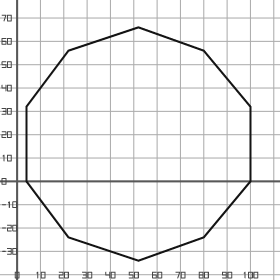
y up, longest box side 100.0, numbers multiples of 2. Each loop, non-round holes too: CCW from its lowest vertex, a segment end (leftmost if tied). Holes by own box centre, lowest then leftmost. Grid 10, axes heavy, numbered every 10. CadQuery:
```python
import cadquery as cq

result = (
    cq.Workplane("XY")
    .moveTo(52.0, -34.0)
    .lineTo(80.0, -24.0)
    .lineTo(100.0, 0.0)
    .lineTo(100.0, 32.0)
    .lineTo(80.0, 56.0)
    .lineTo(52.0, 66.0)
    .lineTo(22.0, 56.0)
    .lineTo(4.0, 32.0)
    .lineTo(4.0, 0.0)
    .lineTo(22.0, -24.0)
    .close()
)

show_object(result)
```